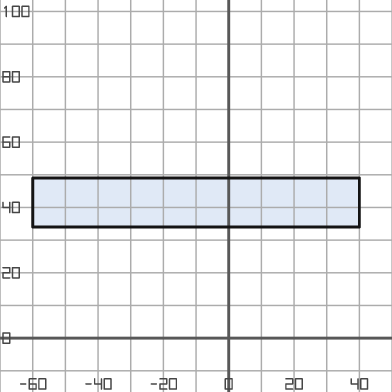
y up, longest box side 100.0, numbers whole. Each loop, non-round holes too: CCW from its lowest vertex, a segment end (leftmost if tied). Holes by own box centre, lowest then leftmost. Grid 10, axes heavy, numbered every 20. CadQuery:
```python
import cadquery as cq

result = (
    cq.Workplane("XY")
    .moveTo(-60.0, 34.0)
    .lineTo(40.0, 34.0)
    .lineTo(40.0, 49.0)
    .lineTo(-60.0, 49.0)
    .close()
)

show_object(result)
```